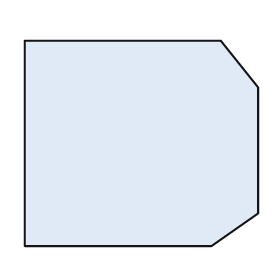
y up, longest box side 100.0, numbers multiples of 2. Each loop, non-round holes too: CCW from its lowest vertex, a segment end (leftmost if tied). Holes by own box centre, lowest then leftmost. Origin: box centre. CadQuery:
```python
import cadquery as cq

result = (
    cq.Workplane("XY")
    .moveTo(-50.0, -44.0)
    .lineTo(30.0, -44.0)
    .lineTo(50.0, -30.0)
    .lineTo(50.0, 24.0)
    .lineTo(34.0, 44.0)
    .lineTo(-50.0, 44.0)
    .close()
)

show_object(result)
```